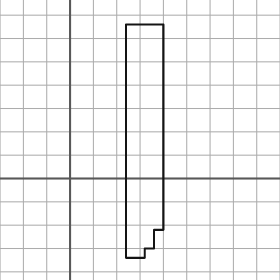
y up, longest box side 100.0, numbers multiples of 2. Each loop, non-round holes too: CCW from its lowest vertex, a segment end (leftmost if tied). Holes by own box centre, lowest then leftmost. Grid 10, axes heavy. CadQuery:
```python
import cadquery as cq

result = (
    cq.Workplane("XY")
    .moveTo(24.0, -34.0)
    .lineTo(32.0, -34.0)
    .lineTo(32.0, -30.0)
    .lineTo(36.0, -30.0)
    .lineTo(36.0, -22.0)
    .lineTo(40.0, -22.0)
    .lineTo(40.0, 66.0)
    .lineTo(24.0, 66.0)
    .close()
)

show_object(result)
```